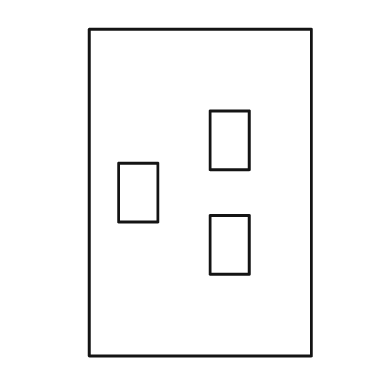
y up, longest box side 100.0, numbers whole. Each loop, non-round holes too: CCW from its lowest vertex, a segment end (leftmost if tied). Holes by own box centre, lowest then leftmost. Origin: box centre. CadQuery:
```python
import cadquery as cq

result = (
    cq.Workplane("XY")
    .moveTo(-34.0, -50.0)
    .lineTo(34.0, -50.0)
    .lineTo(34.0, 50.0)
    .lineTo(-34.0, 50.0)
    .close()
    .moveTo(3.0, -25.0)
    .lineTo(15.0, -25.0)
    .lineTo(15.0, -7.0)
    .lineTo(3.0, -7.0)
    .close()
    .moveTo(-25.0, -9.0)
    .lineTo(-13.0, -9.0)
    .lineTo(-13.0, 9.0)
    .lineTo(-25.0, 9.0)
    .close()
    .moveTo(3.0, 7.0)
    .lineTo(15.0, 7.0)
    .lineTo(15.0, 25.0)
    .lineTo(3.0, 25.0)
    .close()
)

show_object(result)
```